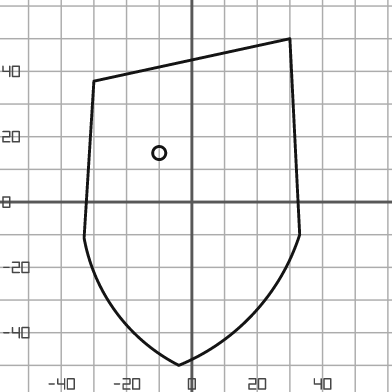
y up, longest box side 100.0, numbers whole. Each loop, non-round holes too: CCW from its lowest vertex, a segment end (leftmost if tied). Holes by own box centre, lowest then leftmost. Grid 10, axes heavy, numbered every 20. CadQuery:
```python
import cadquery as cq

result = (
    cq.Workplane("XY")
    .moveTo(-4.0, -50.0)
    .threePointArc((19.0, -34.0), (33.0, -10.0))
    .lineTo(30.0, 50.0)
    .lineTo(-30.0, 37.0)
    .lineTo(-33.0, -11.0)
    .threePointArc((-23.0, -34.0), (-4.0, -50.0))
    .close()
    .moveTo(-10.0, 15.0)
    .circle(2.0)
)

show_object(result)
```